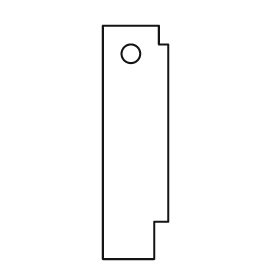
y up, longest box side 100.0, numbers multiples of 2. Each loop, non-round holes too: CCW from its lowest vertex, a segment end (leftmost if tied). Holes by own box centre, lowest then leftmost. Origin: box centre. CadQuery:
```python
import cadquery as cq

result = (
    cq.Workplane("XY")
    .moveTo(-14.0, -50.0)
    .lineTo(8.0, -50.0)
    .lineTo(8.0, -34.0)
    .lineTo(14.0, -34.0)
    .lineTo(14.0, 42.0)
    .lineTo(10.0, 42.0)
    .lineTo(10.0, 50.0)
    .lineTo(-14.0, 50.0)
    .close()
    .moveTo(-2.0, 38.0)
    .circle(4.0)
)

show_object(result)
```